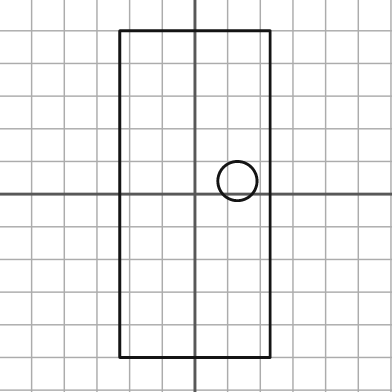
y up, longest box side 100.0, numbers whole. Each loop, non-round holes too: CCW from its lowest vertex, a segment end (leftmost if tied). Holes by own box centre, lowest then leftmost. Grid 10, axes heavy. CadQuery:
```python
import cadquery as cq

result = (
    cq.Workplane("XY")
    .moveTo(-23.0, -50.0)
    .lineTo(23.0, -50.0)
    .lineTo(23.0, 50.0)
    .lineTo(-23.0, 50.0)
    .close()
    .moveTo(13.0, 4.0)
    .circle(6.0)
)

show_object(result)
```